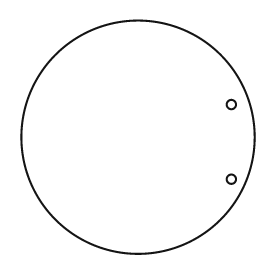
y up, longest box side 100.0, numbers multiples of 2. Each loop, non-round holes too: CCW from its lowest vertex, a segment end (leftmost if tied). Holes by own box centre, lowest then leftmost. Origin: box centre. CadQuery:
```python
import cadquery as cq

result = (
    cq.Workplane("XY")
    .moveTo(0.0, 0.0)
    .circle(50.0)
    .moveTo(40.0, -18.0)
    .circle(2.0)
    .moveTo(40.0, 14.0)
    .circle(2.0)
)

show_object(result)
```